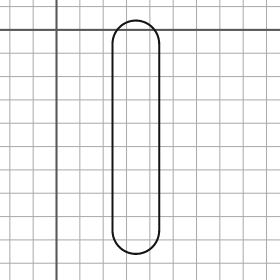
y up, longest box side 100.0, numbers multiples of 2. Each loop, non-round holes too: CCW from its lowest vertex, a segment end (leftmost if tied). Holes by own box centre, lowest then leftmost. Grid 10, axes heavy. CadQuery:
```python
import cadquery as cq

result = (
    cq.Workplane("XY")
    .moveTo(24.0, -86.0)
    .threePointArc((34.0, -96.0), (44.0, -86.0))
    .lineTo(44.0, -6.0)
    .threePointArc((34.0, 4.0), (24.0, -6.0))
    .close()
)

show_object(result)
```